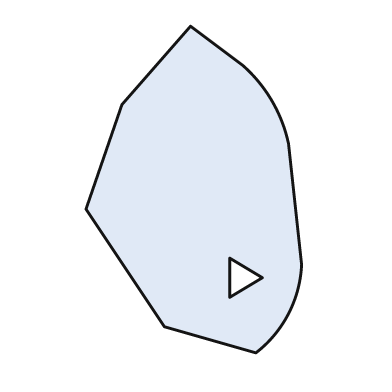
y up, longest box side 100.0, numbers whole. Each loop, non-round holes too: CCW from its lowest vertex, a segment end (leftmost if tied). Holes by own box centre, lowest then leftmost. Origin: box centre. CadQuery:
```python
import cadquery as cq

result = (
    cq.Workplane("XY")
    .moveTo(19.0, -50.0)
    .threePointArc((29.0, -38.0), (33.0, -23.0))
    .lineTo(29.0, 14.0)
    .threePointArc((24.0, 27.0), (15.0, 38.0))
    .lineTo(-1.0, 50.0)
    .lineTo(-22.0, 26.0)
    .lineTo(-33.0, -6.0)
    .lineTo(-9.0, -42.0)
    .close()
    .moveTo(11.0, -33.0)
    .lineTo(21.0, -27.0)
    .lineTo(11.0, -21.0)
    .close()
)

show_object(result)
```